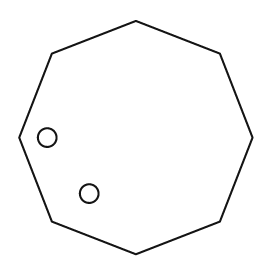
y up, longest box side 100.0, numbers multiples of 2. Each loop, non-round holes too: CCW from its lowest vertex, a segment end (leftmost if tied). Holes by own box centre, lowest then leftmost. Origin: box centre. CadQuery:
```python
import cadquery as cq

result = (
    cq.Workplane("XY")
    .moveTo(0.0, -50.0)
    .lineTo(36.0, -36.0)
    .lineTo(50.0, 0.0)
    .lineTo(36.0, 36.0)
    .lineTo(0.0, 50.0)
    .lineTo(-36.0, 36.0)
    .lineTo(-50.0, 0.0)
    .lineTo(-36.0, -36.0)
    .close()
    .moveTo(-20.0, -24.0)
    .circle(4.0)
    .moveTo(-38.0, 0.0)
    .circle(4.0)
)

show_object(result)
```